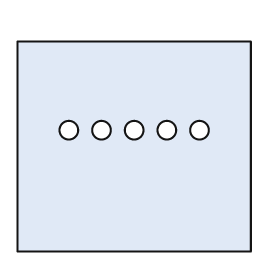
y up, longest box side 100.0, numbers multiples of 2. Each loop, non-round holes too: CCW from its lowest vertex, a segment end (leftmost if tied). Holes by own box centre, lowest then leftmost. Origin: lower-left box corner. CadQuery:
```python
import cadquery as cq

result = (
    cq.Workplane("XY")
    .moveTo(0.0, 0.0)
    .lineTo(100.0, 0.0)
    .lineTo(100.0, 90.0)
    .lineTo(0.0, 90.0)
    .close()
    .moveTo(22.0, 52.0)
    .circle(4.0)
    .moveTo(36.0, 52.0)
    .circle(4.0)
    .moveTo(50.0, 52.0)
    .circle(4.0)
    .moveTo(64.0, 52.0)
    .circle(4.0)
    .moveTo(78.0, 52.0)
    .circle(4.0)
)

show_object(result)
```